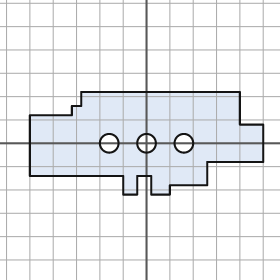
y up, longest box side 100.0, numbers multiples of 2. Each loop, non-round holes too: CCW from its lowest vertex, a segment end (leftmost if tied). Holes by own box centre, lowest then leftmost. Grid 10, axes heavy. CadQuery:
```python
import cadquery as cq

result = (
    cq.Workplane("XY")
    .moveTo(-10.0, -22.0)
    .lineTo(-4.0, -22.0)
    .lineTo(-4.0, -14.0)
    .lineTo(2.0, -14.0)
    .lineTo(2.0, -22.0)
    .lineTo(10.0, -22.0)
    .lineTo(10.0, -18.0)
    .lineTo(26.0, -18.0)
    .lineTo(26.0, -8.0)
    .lineTo(50.0, -8.0)
    .lineTo(50.0, 8.0)
    .lineTo(40.0, 8.0)
    .lineTo(40.0, 22.0)
    .lineTo(-28.0, 22.0)
    .lineTo(-28.0, 16.0)
    .lineTo(-32.0, 16.0)
    .lineTo(-32.0, 12.0)
    .lineTo(-50.0, 12.0)
    .lineTo(-50.0, -14.0)
    .lineTo(-10.0, -14.0)
    .close()
    .moveTo(-16.0, 0.0)
    .circle(4.0)
    .moveTo(0.0, 0.0)
    .circle(4.0)
    .moveTo(16.0, 0.0)
    .circle(4.0)
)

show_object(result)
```